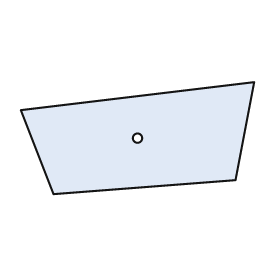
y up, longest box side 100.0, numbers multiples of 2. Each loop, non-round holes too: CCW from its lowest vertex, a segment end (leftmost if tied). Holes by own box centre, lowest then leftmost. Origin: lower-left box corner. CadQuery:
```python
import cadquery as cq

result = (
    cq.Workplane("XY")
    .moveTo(14.0, 0.0)
    .lineTo(92.0, 6.0)
    .lineTo(100.0, 48.0)
    .lineTo(0.0, 36.0)
    .close()
    .moveTo(50.0, 24.0)
    .circle(2.0)
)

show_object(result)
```